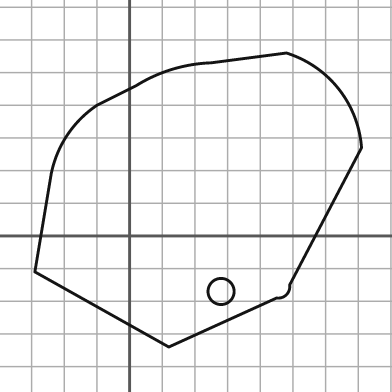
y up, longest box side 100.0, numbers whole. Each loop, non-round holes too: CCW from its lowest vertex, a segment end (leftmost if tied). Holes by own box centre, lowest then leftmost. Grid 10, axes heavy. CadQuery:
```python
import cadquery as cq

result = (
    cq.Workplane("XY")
    .moveTo(12.0, -34.0)
    .lineTo(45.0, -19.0)
    .threePointArc((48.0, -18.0), (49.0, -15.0))
    .lineTo(71.0, 27.0)
    .threePointArc((64.0, 45.0), (48.0, 56.0))
    .lineTo(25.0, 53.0)
    .threePointArc((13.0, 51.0), (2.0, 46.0))
    .lineTo(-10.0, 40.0)
    .threePointArc((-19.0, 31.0), (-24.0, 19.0))
    .lineTo(-29.0, -11.0)
    .close()
    .moveTo(28.0, -17.0)
    .circle(4.0)
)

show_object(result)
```